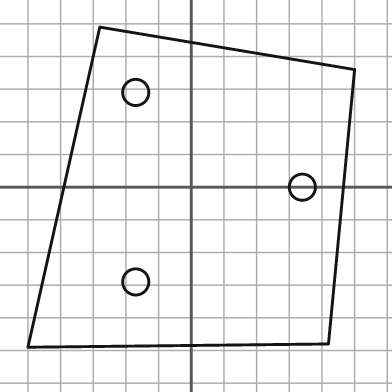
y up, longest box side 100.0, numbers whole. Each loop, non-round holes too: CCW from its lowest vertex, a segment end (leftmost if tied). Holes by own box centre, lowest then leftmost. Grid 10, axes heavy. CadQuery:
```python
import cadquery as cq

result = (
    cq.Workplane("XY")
    .moveTo(-50.0, -49.0)
    .lineTo(42.0, -48.0)
    .lineTo(50.0, 36.0)
    .lineTo(-28.0, 49.0)
    .close()
    .moveTo(-17.0, -29.0)
    .circle(4.0)
    .moveTo(34.0, 0.0)
    .circle(4.0)
    .moveTo(-17.0, 29.0)
    .circle(4.0)
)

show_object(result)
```